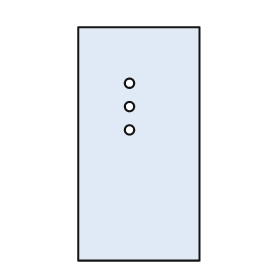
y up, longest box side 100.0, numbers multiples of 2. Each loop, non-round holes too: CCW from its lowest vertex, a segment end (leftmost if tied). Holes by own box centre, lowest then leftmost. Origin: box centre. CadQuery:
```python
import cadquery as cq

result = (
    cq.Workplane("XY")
    .moveTo(-26.0, -50.0)
    .lineTo(26.0, -50.0)
    .lineTo(26.0, 50.0)
    .lineTo(-26.0, 50.0)
    .close()
    .moveTo(-4.0, 6.0)
    .circle(2.0)
    .moveTo(-4.0, 16.0)
    .circle(2.0)
    .moveTo(-4.0, 26.0)
    .circle(2.0)
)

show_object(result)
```